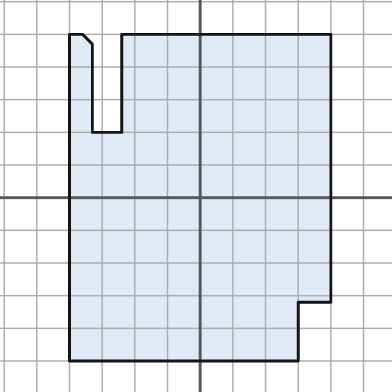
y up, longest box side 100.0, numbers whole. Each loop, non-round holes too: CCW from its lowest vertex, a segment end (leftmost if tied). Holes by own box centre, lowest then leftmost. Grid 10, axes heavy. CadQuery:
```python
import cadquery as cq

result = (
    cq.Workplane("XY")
    .moveTo(-40.0, -50.0)
    .lineTo(30.0, -50.0)
    .lineTo(30.0, -32.0)
    .lineTo(40.0, -32.0)
    .lineTo(40.0, 50.0)
    .lineTo(-24.0, 50.0)
    .lineTo(-24.0, 20.0)
    .lineTo(-33.0, 20.0)
    .lineTo(-33.0, 47.0)
    .lineTo(-36.0, 50.0)
    .lineTo(-40.0, 50.0)
    .close()
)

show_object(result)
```